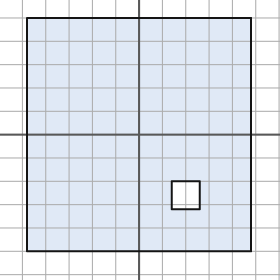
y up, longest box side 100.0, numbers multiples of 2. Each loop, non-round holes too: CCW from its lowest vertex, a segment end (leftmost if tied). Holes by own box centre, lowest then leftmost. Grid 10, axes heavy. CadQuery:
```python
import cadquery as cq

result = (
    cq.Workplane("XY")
    .moveTo(-48.0, -50.0)
    .lineTo(48.0, -50.0)
    .lineTo(48.0, 50.0)
    .lineTo(-48.0, 50.0)
    .close()
    .moveTo(14.0, -32.0)
    .lineTo(26.0, -32.0)
    .lineTo(26.0, -20.0)
    .lineTo(14.0, -20.0)
    .close()
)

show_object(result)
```